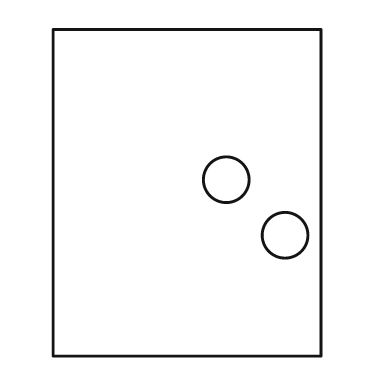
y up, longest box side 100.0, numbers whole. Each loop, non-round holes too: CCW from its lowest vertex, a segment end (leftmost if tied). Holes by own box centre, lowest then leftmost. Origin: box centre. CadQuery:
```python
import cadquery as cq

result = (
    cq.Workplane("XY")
    .moveTo(-41.0, -50.0)
    .lineTo(41.0, -50.0)
    .lineTo(41.0, 50.0)
    .lineTo(-41.0, 50.0)
    .close()
    .moveTo(30.0, -13.0)
    .circle(7.0)
    .moveTo(12.0, 4.0)
    .circle(7.0)
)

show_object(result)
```